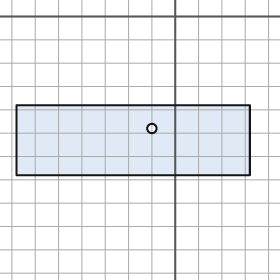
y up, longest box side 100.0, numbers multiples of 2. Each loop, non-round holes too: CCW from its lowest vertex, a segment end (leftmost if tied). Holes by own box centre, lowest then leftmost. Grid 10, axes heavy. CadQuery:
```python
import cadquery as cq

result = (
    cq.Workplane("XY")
    .moveTo(-68.0, -68.0)
    .lineTo(32.0, -68.0)
    .lineTo(32.0, -38.0)
    .lineTo(-68.0, -38.0)
    .close()
    .moveTo(-10.0, -48.0)
    .circle(2.0)
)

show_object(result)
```